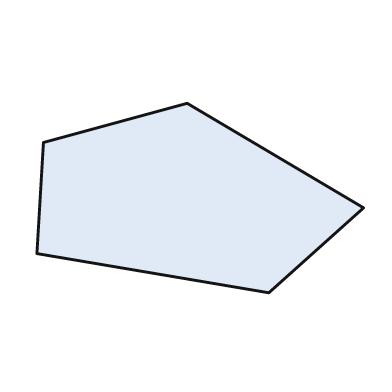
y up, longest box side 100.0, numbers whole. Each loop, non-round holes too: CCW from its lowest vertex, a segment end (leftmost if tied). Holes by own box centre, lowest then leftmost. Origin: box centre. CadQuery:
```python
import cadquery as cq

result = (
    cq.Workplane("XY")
    .moveTo(21.0, -29.0)
    .lineTo(50.0, -3.0)
    .lineTo(-4.0, 29.0)
    .lineTo(-48.0, 17.0)
    .lineTo(-50.0, -17.0)
    .close()
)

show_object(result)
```